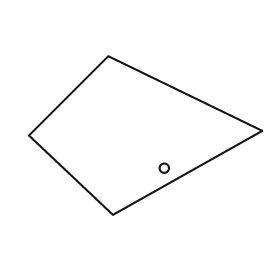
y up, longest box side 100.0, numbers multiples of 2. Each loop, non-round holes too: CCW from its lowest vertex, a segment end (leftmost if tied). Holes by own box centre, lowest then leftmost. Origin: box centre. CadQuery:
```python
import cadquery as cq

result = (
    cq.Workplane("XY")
    .moveTo(-14.0, -34.0)
    .lineTo(50.0, 2.0)
    .lineTo(-16.0, 34.0)
    .lineTo(-50.0, 0.0)
    .close()
    .moveTo(8.0, -14.0)
    .circle(2.0)
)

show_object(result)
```